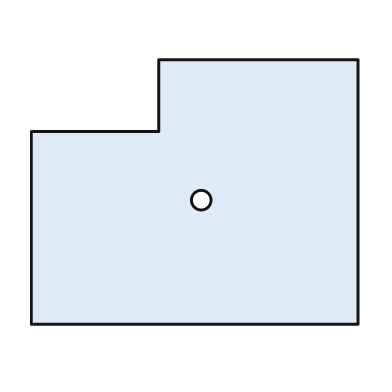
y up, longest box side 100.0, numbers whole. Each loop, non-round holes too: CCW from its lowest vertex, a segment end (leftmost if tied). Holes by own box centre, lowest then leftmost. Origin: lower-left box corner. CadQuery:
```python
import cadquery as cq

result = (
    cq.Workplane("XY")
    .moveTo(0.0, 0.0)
    .lineTo(100.0, 0.0)
    .lineTo(100.0, 81.0)
    .lineTo(39.0, 81.0)
    .lineTo(39.0, 59.0)
    .lineTo(0.0, 59.0)
    .close()
    .moveTo(52.0, 38.0)
    .circle(3.0)
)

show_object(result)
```